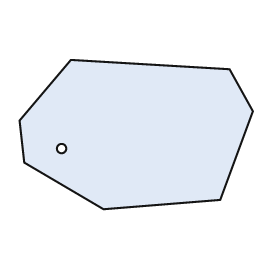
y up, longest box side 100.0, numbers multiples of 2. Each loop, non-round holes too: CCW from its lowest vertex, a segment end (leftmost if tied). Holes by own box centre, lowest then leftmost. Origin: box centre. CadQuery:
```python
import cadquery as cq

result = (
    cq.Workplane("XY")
    .moveTo(-14.0, -32.0)
    .lineTo(36.0, -28.0)
    .lineTo(50.0, 10.0)
    .lineTo(40.0, 28.0)
    .lineTo(-28.0, 32.0)
    .lineTo(-50.0, 6.0)
    .lineTo(-48.0, -12.0)
    .close()
    .moveTo(-32.0, -6.0)
    .circle(2.0)
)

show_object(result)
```